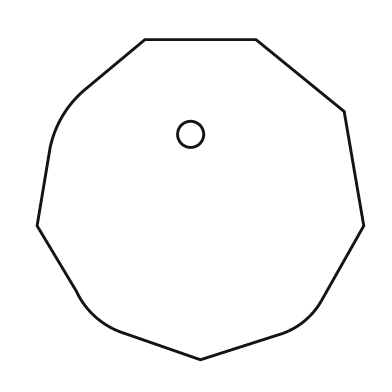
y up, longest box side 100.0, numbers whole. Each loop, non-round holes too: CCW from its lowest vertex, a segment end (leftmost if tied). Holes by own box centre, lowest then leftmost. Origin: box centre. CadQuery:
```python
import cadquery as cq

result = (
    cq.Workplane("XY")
    .moveTo(0.0, -49.0)
    .lineTo(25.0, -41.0)
    .threePointArc((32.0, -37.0), (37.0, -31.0))
    .lineTo(50.0, -8.0)
    .lineTo(44.0, 27.0)
    .lineTo(17.0, 49.0)
    .lineTo(-17.0, 49.0)
    .lineTo(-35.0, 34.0)
    .threePointArc((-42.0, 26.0), (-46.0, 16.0))
    .lineTo(-50.0, -8.0)
    .lineTo(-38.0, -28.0)
    .threePointArc((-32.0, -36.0), (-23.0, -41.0))
    .close()
    .moveTo(-3.0, 20.0)
    .circle(4.0)
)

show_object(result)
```